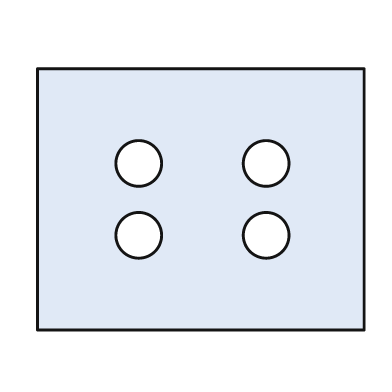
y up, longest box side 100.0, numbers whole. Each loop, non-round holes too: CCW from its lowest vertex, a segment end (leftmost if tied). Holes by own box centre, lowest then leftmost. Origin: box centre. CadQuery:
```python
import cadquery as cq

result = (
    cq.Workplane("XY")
    .moveTo(-50.0, -40.0)
    .lineTo(50.0, -40.0)
    .lineTo(50.0, 40.0)
    .lineTo(-50.0, 40.0)
    .close()
    .moveTo(-19.0, -11.0)
    .circle(7.0)
    .moveTo(20.0, -11.0)
    .circle(7.0)
    .moveTo(-19.0, 11.0)
    .circle(7.0)
    .moveTo(20.0, 11.0)
    .circle(7.0)
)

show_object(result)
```